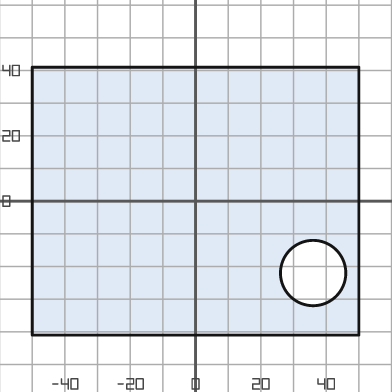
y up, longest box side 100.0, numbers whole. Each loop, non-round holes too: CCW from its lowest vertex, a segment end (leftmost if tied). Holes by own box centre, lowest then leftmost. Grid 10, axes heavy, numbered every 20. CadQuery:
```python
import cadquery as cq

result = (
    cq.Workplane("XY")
    .moveTo(-50.0, -41.0)
    .lineTo(50.0, -41.0)
    .lineTo(50.0, 41.0)
    .lineTo(-50.0, 41.0)
    .close()
    .moveTo(36.0, -22.0)
    .circle(10.0)
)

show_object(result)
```